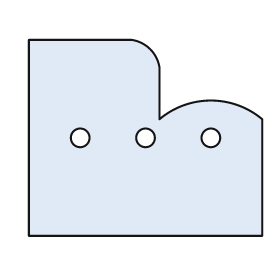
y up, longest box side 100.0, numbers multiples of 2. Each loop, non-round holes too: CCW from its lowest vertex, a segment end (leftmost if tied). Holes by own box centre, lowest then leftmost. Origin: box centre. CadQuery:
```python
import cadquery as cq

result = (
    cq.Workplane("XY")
    .moveTo(-50.0, -42.0)
    .lineTo(50.0, -42.0)
    .lineTo(50.0, 8.0)
    .threePointArc((28.0, 16.0), (6.0, 8.0))
    .lineTo(6.0, 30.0)
    .threePointArc((2.0, 38.0), (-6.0, 42.0))
    .lineTo(-50.0, 42.0)
    .close()
    .moveTo(-28.0, 0.0)
    .circle(4.0)
    .moveTo(0.0, 0.0)
    .circle(4.0)
    .moveTo(28.0, 0.0)
    .circle(4.0)
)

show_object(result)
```